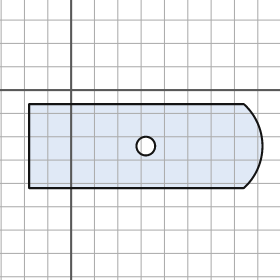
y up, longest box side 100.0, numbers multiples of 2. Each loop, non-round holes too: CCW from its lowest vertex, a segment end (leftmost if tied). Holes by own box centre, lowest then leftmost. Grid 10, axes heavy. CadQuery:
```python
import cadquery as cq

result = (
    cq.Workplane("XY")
    .moveTo(-18.0, -42.0)
    .lineTo(74.0, -42.0)
    .threePointArc((82.0, -24.0), (74.0, -6.0))
    .lineTo(-18.0, -6.0)
    .close()
    .moveTo(32.0, -24.0)
    .circle(4.0)
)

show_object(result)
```